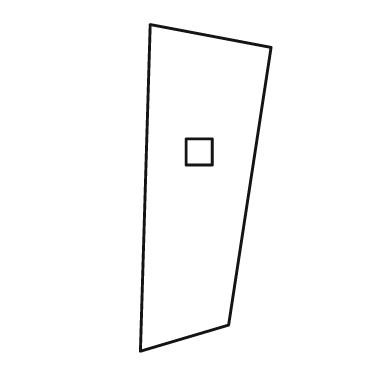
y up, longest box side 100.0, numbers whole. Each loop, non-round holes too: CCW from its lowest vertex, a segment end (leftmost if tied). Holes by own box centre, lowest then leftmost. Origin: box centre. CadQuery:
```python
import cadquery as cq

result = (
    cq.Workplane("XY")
    .moveTo(-20.0, -50.0)
    .lineTo(7.0, -42.0)
    .lineTo(20.0, 43.0)
    .lineTo(-17.0, 50.0)
    .close()
    .moveTo(-6.0, 7.0)
    .lineTo(2.0, 7.0)
    .lineTo(2.0, 15.0)
    .lineTo(-6.0, 15.0)
    .close()
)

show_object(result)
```